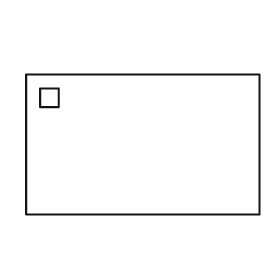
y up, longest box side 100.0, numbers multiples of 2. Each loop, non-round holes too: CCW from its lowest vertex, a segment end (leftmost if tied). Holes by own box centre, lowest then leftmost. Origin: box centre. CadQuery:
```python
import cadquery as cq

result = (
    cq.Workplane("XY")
    .moveTo(-50.0, -30.0)
    .lineTo(50.0, -30.0)
    .lineTo(50.0, 30.0)
    .lineTo(-50.0, 30.0)
    .close()
    .moveTo(-44.0, 16.0)
    .lineTo(-36.0, 16.0)
    .lineTo(-36.0, 24.0)
    .lineTo(-44.0, 24.0)
    .close()
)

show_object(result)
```